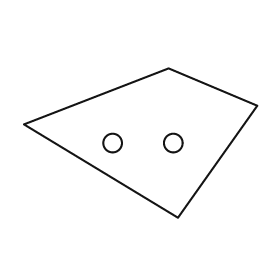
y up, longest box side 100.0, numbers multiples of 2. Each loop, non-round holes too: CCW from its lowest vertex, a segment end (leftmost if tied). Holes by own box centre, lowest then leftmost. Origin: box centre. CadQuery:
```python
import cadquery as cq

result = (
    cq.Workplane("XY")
    .moveTo(16.0, -32.0)
    .lineTo(50.0, 16.0)
    .lineTo(12.0, 32.0)
    .lineTo(-50.0, 8.0)
    .close()
    .moveTo(-12.0, 0.0)
    .circle(4.0)
    .moveTo(14.0, 0.0)
    .circle(4.0)
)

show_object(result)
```